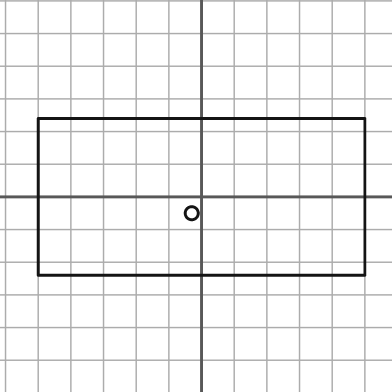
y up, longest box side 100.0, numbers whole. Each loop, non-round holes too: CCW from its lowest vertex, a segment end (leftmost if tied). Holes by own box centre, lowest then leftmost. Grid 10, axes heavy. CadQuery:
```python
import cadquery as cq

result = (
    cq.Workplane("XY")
    .moveTo(-50.0, -24.0)
    .lineTo(50.0, -24.0)
    .lineTo(50.0, 24.0)
    .lineTo(-50.0, 24.0)
    .close()
    .moveTo(-3.0, -5.0)
    .circle(2.0)
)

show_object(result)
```